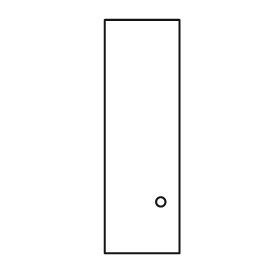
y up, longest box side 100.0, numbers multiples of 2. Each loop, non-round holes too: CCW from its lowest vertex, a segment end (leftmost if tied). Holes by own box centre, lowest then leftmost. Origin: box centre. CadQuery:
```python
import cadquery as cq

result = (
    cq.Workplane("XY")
    .moveTo(-16.0, -50.0)
    .lineTo(16.0, -50.0)
    .lineTo(16.0, 50.0)
    .lineTo(-16.0, 50.0)
    .close()
    .moveTo(8.0, -28.0)
    .circle(2.0)
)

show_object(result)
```